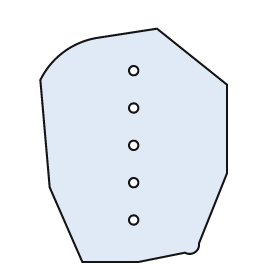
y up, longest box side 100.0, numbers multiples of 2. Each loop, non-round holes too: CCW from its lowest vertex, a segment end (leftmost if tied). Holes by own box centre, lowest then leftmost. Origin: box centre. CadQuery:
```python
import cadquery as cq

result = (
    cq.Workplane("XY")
    .moveTo(-22.0, -50.0)
    .lineTo(2.0, -50.0)
    .lineTo(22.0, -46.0)
    .threePointArc((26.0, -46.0), (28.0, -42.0))
    .lineTo(40.0, -12.0)
    .lineTo(40.0, 26.0)
    .lineTo(10.0, 50.0)
    .lineTo(-16.0, 46.0)
    .threePointArc((-30.0, 40.0), (-40.0, 28.0))
    .lineTo(-36.0, -18.0)
    .close()
    .moveTo(0.0, -32.0)
    .circle(2.0)
    .moveTo(0.0, -16.0)
    .circle(2.0)
    .moveTo(0.0, 0.0)
    .circle(2.0)
    .moveTo(0.0, 16.0)
    .circle(2.0)
    .moveTo(0.0, 32.0)
    .circle(2.0)
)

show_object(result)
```